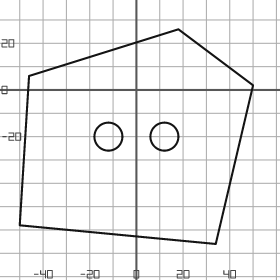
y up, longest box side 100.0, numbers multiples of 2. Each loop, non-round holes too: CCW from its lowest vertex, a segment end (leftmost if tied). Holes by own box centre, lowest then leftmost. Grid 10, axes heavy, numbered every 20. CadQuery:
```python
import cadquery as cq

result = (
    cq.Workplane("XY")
    .moveTo(34.0, -66.0)
    .lineTo(50.0, 2.0)
    .lineTo(18.0, 26.0)
    .lineTo(-46.0, 6.0)
    .lineTo(-50.0, -58.0)
    .close()
    .moveTo(-12.0, -20.0)
    .circle(6.0)
    .moveTo(12.0, -20.0)
    .circle(6.0)
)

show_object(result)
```